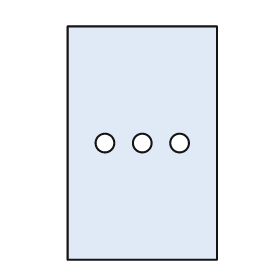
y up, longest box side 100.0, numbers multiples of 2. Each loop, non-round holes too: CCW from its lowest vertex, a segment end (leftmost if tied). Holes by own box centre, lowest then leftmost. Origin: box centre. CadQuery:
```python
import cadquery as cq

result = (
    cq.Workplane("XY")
    .moveTo(-32.0, -50.0)
    .lineTo(32.0, -50.0)
    .lineTo(32.0, 50.0)
    .lineTo(-32.0, 50.0)
    .close()
    .moveTo(-16.0, 0.0)
    .circle(4.0)
    .moveTo(0.0, 0.0)
    .circle(4.0)
    .moveTo(16.0, 0.0)
    .circle(4.0)
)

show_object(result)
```